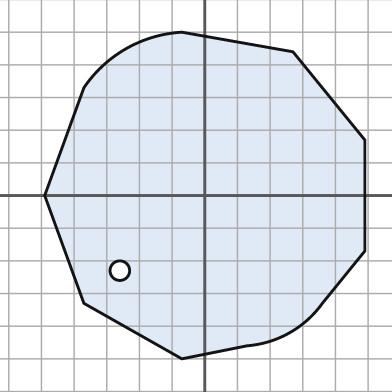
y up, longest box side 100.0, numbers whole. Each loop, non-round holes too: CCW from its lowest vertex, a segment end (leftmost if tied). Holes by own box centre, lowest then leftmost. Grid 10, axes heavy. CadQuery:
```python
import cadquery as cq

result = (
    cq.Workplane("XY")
    .moveTo(-7.0, -50.0)
    .lineTo(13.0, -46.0)
    .threePointArc((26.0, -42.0), (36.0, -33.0))
    .lineTo(49.0, -17.0)
    .lineTo(49.0, 17.0)
    .lineTo(27.0, 44.0)
    .lineTo(-7.0, 50.0)
    .threePointArc((-24.0, 45.0), (-37.0, 33.0))
    .lineTo(-49.0, 0.0)
    .lineTo(-37.0, -33.0)
    .close()
    .moveTo(-26.0, -23.0)
    .circle(3.0)
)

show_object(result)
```